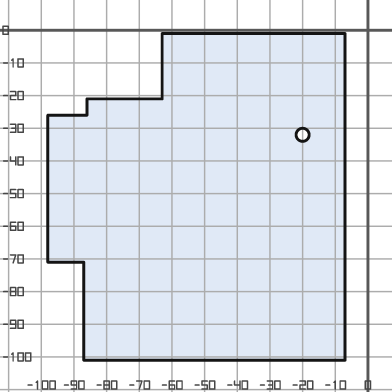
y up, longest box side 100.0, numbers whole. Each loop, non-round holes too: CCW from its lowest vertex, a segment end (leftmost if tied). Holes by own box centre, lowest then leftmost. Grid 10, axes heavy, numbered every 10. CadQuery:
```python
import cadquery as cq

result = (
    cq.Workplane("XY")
    .moveTo(-87.0, -101.0)
    .lineTo(-7.0, -101.0)
    .lineTo(-7.0, -1.0)
    .lineTo(-63.0, -1.0)
    .lineTo(-63.0, -21.0)
    .lineTo(-86.0, -21.0)
    .lineTo(-86.0, -26.0)
    .lineTo(-98.0, -26.0)
    .lineTo(-98.0, -71.0)
    .lineTo(-87.0, -71.0)
    .close()
    .moveTo(-20.0, -32.0)
    .circle(2.0)
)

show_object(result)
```